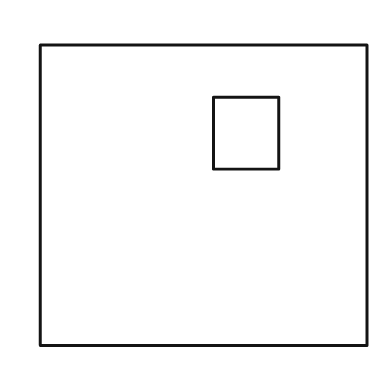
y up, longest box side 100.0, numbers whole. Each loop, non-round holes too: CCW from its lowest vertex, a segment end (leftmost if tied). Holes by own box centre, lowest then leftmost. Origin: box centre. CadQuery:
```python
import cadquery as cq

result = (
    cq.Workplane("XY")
    .moveTo(-50.0, -46.0)
    .lineTo(50.0, -46.0)
    .lineTo(50.0, 46.0)
    .lineTo(-50.0, 46.0)
    .close()
    .moveTo(3.0, 8.0)
    .lineTo(23.0, 8.0)
    .lineTo(23.0, 30.0)
    .lineTo(3.0, 30.0)
    .close()
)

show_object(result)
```